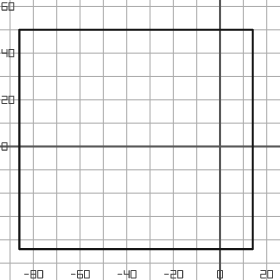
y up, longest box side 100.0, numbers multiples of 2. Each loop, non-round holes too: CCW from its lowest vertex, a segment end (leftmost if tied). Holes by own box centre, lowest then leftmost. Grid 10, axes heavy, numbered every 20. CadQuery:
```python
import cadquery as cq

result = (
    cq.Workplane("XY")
    .moveTo(-86.0, -44.0)
    .lineTo(14.0, -44.0)
    .lineTo(14.0, 50.0)
    .lineTo(-86.0, 50.0)
    .close()
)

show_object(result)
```